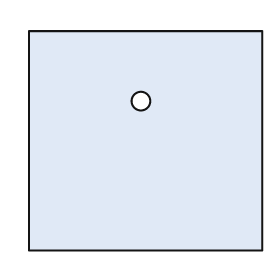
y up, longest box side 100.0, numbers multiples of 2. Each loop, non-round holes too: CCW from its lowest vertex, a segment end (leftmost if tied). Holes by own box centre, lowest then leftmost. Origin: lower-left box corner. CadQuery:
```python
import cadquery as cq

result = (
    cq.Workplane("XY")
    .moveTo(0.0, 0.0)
    .lineTo(100.0, 0.0)
    .lineTo(100.0, 94.0)
    .lineTo(0.0, 94.0)
    .close()
    .moveTo(48.0, 64.0)
    .circle(4.0)
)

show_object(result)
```